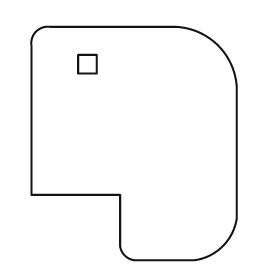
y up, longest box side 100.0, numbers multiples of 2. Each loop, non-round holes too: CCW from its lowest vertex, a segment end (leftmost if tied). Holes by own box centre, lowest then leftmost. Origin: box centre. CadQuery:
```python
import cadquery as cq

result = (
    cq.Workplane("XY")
    .moveTo(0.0, -50.0)
    .lineTo(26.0, -50.0)
    .threePointArc((38.0, -44.0), (44.0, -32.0))
    .lineTo(44.0, 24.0)
    .threePointArc((36.0, 42.0), (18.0, 50.0))
    .lineTo(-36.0, 50.0)
    .threePointArc((-42.0, 48.0), (-44.0, 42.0))
    .lineTo(-44.0, -22.0)
    .lineTo(-6.0, -22.0)
    .lineTo(-6.0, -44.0)
    .threePointArc((-4.0, -48.0), (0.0, -50.0))
    .close()
    .moveTo(-24.0, 30.0)
    .lineTo(-16.0, 30.0)
    .lineTo(-16.0, 38.0)
    .lineTo(-24.0, 38.0)
    .close()
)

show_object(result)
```